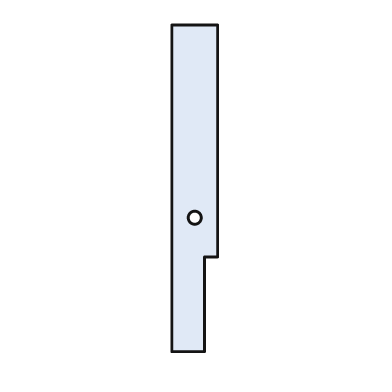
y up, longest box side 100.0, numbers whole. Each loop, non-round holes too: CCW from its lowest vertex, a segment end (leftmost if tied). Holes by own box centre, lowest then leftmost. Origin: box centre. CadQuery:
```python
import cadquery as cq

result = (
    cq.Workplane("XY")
    .moveTo(-7.0, -50.0)
    .lineTo(3.0, -50.0)
    .lineTo(3.0, -21.0)
    .lineTo(7.0, -21.0)
    .lineTo(7.0, 50.0)
    .lineTo(-7.0, 50.0)
    .close()
    .moveTo(0.0, -9.0)
    .circle(2.0)
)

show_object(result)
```